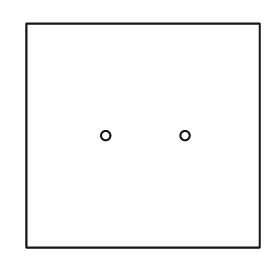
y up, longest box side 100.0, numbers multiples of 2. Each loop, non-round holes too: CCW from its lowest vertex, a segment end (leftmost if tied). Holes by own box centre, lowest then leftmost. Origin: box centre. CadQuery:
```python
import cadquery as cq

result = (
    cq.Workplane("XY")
    .moveTo(-50.0, -48.0)
    .lineTo(50.0, -48.0)
    .lineTo(50.0, 48.0)
    .lineTo(-50.0, 48.0)
    .close()
    .moveTo(-16.0, 0.0)
    .circle(2.0)
    .moveTo(18.0, 0.0)
    .circle(2.0)
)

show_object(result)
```